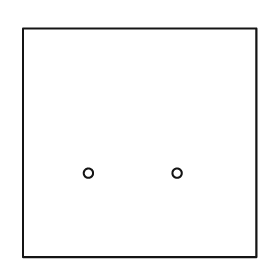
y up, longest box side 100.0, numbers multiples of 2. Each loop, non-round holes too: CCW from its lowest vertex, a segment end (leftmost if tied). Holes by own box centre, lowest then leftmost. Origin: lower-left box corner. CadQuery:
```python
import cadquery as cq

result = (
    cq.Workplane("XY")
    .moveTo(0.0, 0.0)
    .lineTo(100.0, 0.0)
    .lineTo(100.0, 98.0)
    .lineTo(0.0, 98.0)
    .close()
    .moveTo(28.0, 36.0)
    .circle(2.0)
    .moveTo(66.0, 36.0)
    .circle(2.0)
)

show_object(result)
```